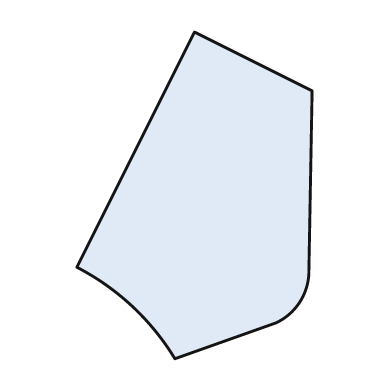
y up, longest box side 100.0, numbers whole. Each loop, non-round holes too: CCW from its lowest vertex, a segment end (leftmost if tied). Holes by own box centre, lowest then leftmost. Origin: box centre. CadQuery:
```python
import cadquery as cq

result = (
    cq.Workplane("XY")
    .moveTo(-6.0, -50.0)
    .lineTo(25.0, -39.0)
    .threePointArc((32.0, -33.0), (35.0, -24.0))
    .lineTo(36.0, 32.0)
    .lineTo(0.0, 50.0)
    .lineTo(-36.0, -22.0)
    .threePointArc((-19.0, -34.0), (-6.0, -50.0))
    .close()
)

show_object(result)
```